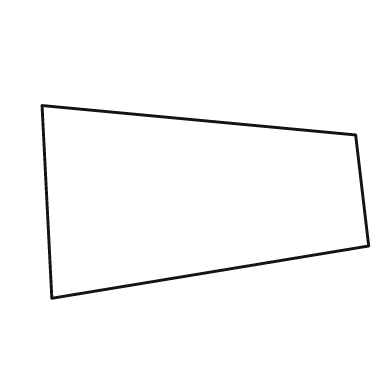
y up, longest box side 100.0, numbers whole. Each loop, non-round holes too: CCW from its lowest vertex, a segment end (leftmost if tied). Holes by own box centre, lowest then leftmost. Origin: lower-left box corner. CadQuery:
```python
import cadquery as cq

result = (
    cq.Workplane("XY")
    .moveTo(3.0, 0.0)
    .lineTo(100.0, 16.0)
    .lineTo(96.0, 50.0)
    .lineTo(0.0, 59.0)
    .close()
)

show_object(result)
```